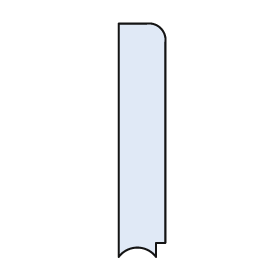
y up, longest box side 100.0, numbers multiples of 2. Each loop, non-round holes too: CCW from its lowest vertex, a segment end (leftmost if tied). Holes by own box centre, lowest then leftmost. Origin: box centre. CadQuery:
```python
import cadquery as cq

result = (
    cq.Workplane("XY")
    .moveTo(-10.0, -50.0)
    .threePointArc((-2.0, -46.0), (6.0, -50.0))
    .lineTo(6.0, -44.0)
    .lineTo(10.0, -44.0)
    .lineTo(10.0, 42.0)
    .threePointArc((8.0, 48.0), (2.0, 50.0))
    .lineTo(-10.0, 50.0)
    .close()
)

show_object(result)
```